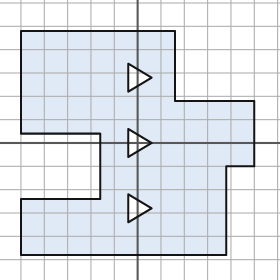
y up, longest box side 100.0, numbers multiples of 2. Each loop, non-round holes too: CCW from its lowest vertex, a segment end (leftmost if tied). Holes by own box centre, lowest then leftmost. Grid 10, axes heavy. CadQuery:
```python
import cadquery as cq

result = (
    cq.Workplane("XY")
    .moveTo(-50.0, -48.0)
    .lineTo(38.0, -48.0)
    .lineTo(38.0, -10.0)
    .lineTo(50.0, -10.0)
    .lineTo(50.0, 18.0)
    .lineTo(16.0, 18.0)
    .lineTo(16.0, 48.0)
    .lineTo(-50.0, 48.0)
    .lineTo(-50.0, 4.0)
    .lineTo(-16.0, 4.0)
    .lineTo(-16.0, -24.0)
    .lineTo(-50.0, -24.0)
    .close()
    .moveTo(-4.0, -34.0)
    .lineTo(6.0, -28.0)
    .lineTo(-4.0, -22.0)
    .close()
    .moveTo(-4.0, -6.0)
    .lineTo(6.0, 0.0)
    .lineTo(-4.0, 6.0)
    .close()
    .moveTo(-4.0, 22.0)
    .lineTo(6.0, 28.0)
    .lineTo(-4.0, 34.0)
    .close()
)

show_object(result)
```